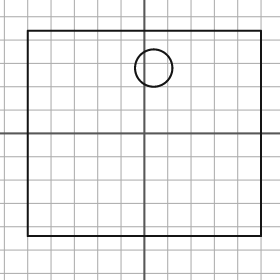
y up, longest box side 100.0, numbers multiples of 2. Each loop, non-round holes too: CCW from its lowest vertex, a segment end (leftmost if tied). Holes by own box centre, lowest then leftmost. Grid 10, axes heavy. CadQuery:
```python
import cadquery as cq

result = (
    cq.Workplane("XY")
    .moveTo(-50.0, -44.0)
    .lineTo(50.0, -44.0)
    .lineTo(50.0, 44.0)
    .lineTo(-50.0, 44.0)
    .close()
    .moveTo(4.0, 28.0)
    .circle(8.0)
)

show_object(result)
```